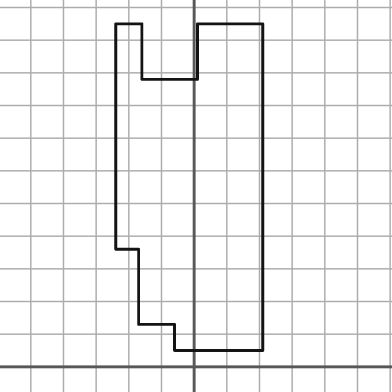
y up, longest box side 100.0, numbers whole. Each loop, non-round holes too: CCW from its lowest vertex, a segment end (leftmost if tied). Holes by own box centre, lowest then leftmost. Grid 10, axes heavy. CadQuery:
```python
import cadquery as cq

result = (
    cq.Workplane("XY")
    .moveTo(-6.0, 5.0)
    .lineTo(21.0, 5.0)
    .lineTo(21.0, 105.0)
    .lineTo(1.0, 105.0)
    .lineTo(1.0, 88.0)
    .lineTo(-16.0, 88.0)
    .lineTo(-16.0, 105.0)
    .lineTo(-24.0, 105.0)
    .lineTo(-24.0, 36.0)
    .lineTo(-17.0, 36.0)
    .lineTo(-17.0, 13.0)
    .lineTo(-6.0, 13.0)
    .close()
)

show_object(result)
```